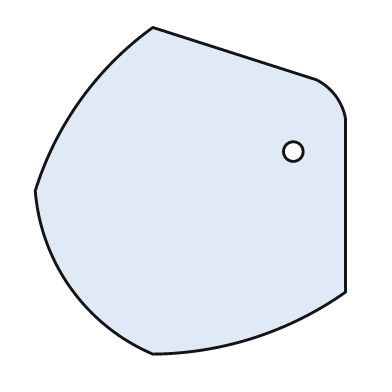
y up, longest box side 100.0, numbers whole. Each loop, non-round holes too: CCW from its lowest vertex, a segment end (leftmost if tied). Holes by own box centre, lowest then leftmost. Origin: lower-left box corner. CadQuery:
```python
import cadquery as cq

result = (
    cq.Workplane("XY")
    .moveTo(36.0, 0.0)
    .threePointArc((67.0, 5.0), (95.0, 19.0))
    .lineTo(95.0, 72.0)
    .threePointArc((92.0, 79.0), (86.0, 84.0))
    .lineTo(36.0, 100.0)
    .threePointArc((14.0, 78.0), (0.0, 50.0))
    .threePointArc((11.0, 20.0), (36.0, 0.0))
    .close()
    .moveTo(79.0, 62.0)
    .circle(3.0)
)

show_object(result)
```